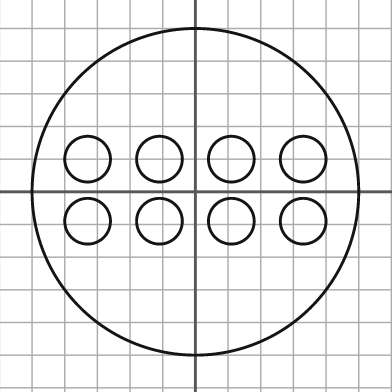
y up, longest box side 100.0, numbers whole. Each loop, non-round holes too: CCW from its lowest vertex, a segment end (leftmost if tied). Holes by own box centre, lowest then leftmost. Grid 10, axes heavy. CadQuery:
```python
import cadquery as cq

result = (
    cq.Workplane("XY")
    .moveTo(0.0, 0.0)
    .circle(50.0)
    .moveTo(-33.0, -9.0)
    .circle(7.0)
    .moveTo(-11.0, -9.0)
    .circle(7.0)
    .moveTo(11.0, -9.0)
    .circle(7.0)
    .moveTo(33.0, -9.0)
    .circle(7.0)
    .moveTo(-33.0, 10.0)
    .circle(7.0)
    .moveTo(-11.0, 10.0)
    .circle(7.0)
    .moveTo(11.0, 10.0)
    .circle(7.0)
    .moveTo(33.0, 10.0)
    .circle(7.0)
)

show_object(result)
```